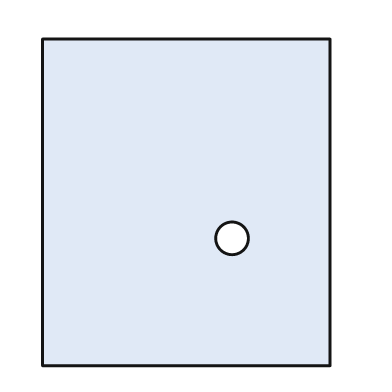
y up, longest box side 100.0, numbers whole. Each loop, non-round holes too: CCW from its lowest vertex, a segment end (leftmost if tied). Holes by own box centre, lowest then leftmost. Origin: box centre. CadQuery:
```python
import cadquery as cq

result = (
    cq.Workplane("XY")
    .moveTo(-44.0, -50.0)
    .lineTo(44.0, -50.0)
    .lineTo(44.0, 50.0)
    .lineTo(-44.0, 50.0)
    .close()
    .moveTo(14.0, -11.0)
    .circle(5.0)
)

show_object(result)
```